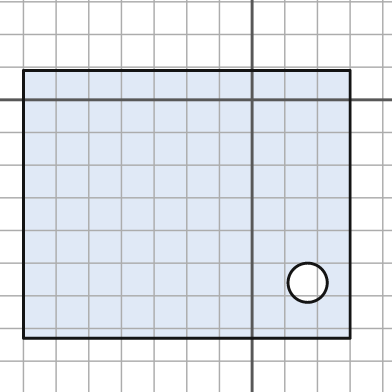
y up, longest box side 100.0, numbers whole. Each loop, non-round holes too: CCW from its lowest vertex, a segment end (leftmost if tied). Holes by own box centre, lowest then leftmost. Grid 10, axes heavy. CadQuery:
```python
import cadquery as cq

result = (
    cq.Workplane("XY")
    .moveTo(-70.0, -73.0)
    .lineTo(30.0, -73.0)
    .lineTo(30.0, 9.0)
    .lineTo(-70.0, 9.0)
    .close()
    .moveTo(17.0, -56.0)
    .circle(6.0)
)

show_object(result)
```